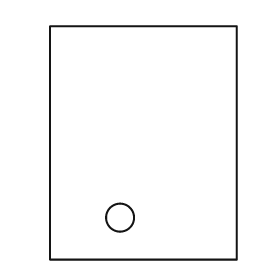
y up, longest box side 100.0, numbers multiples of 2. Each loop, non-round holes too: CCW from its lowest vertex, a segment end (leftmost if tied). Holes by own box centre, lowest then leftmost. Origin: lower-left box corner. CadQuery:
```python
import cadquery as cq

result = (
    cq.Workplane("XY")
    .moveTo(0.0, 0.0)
    .lineTo(80.0, 0.0)
    .lineTo(80.0, 100.0)
    .lineTo(0.0, 100.0)
    .close()
    .moveTo(30.0, 18.0)
    .circle(6.0)
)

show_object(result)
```